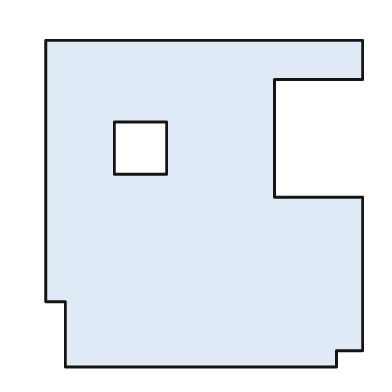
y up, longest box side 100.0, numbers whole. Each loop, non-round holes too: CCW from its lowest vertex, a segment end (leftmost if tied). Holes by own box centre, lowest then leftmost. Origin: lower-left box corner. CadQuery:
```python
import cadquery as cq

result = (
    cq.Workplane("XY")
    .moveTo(6.0, 0.0)
    .lineTo(89.0, 0.0)
    .lineTo(89.0, 5.0)
    .lineTo(97.0, 5.0)
    .lineTo(97.0, 52.0)
    .lineTo(70.0, 52.0)
    .lineTo(70.0, 88.0)
    .lineTo(97.0, 88.0)
    .lineTo(97.0, 100.0)
    .lineTo(0.0, 100.0)
    .lineTo(0.0, 20.0)
    .lineTo(6.0, 20.0)
    .close()
    .moveTo(21.0, 59.0)
    .lineTo(37.0, 59.0)
    .lineTo(37.0, 75.0)
    .lineTo(21.0, 75.0)
    .close()
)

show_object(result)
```